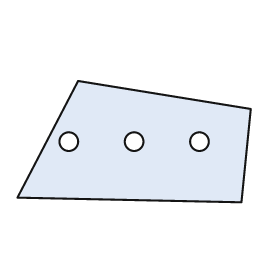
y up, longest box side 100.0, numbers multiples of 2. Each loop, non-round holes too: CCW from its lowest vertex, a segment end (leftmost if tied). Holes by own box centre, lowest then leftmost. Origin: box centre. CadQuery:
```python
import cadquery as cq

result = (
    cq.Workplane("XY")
    .moveTo(46.0, -26.0)
    .lineTo(50.0, 14.0)
    .lineTo(-24.0, 26.0)
    .lineTo(-50.0, -24.0)
    .close()
    .moveTo(-28.0, 0.0)
    .circle(4.0)
    .moveTo(0.0, 0.0)
    .circle(4.0)
    .moveTo(28.0, 0.0)
    .circle(4.0)
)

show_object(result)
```